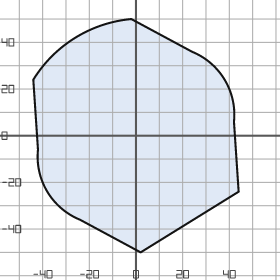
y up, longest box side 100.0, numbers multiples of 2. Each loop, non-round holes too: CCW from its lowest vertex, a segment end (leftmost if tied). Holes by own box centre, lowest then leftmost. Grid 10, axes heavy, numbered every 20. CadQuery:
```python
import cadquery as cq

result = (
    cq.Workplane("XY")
    .moveTo(2.0, -50.0)
    .lineTo(44.0, -24.0)
    .lineTo(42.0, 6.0)
    .threePointArc((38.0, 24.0), (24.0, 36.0))
    .lineTo(-2.0, 50.0)
    .threePointArc((-26.0, 42.0), (-44.0, 24.0))
    .lineTo(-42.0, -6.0)
    .threePointArc((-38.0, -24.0), (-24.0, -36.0))
    .close()
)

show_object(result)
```